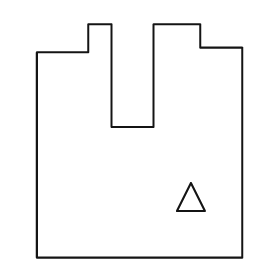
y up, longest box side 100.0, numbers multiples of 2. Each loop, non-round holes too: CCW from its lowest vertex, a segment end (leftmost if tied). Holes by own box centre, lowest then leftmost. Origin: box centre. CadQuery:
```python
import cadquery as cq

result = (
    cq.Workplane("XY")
    .moveTo(-44.0, -50.0)
    .lineTo(44.0, -50.0)
    .lineTo(44.0, 40.0)
    .lineTo(26.0, 40.0)
    .lineTo(26.0, 50.0)
    .lineTo(6.0, 50.0)
    .lineTo(6.0, 6.0)
    .lineTo(-12.0, 6.0)
    .lineTo(-12.0, 50.0)
    .lineTo(-22.0, 50.0)
    .lineTo(-22.0, 38.0)
    .lineTo(-44.0, 38.0)
    .close()
    .moveTo(16.0, -30.0)
    .lineTo(28.0, -30.0)
    .lineTo(22.0, -18.0)
    .close()
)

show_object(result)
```